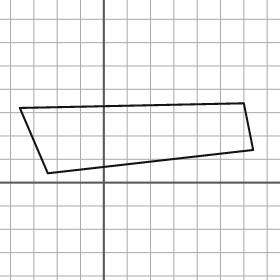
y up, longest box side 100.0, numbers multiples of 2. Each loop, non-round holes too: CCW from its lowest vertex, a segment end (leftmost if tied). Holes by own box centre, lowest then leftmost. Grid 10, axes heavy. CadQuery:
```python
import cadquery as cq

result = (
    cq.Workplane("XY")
    .moveTo(-24.0, 4.0)
    .lineTo(64.0, 14.0)
    .lineTo(60.0, 34.0)
    .lineTo(-36.0, 32.0)
    .close()
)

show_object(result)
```